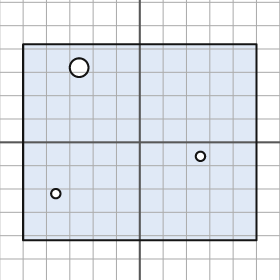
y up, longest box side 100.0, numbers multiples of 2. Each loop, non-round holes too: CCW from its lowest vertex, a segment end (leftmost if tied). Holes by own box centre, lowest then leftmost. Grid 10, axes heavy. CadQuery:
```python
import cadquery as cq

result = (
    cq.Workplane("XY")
    .moveTo(-50.0, -42.0)
    .lineTo(50.0, -42.0)
    .lineTo(50.0, 42.0)
    .lineTo(-50.0, 42.0)
    .close()
    .moveTo(-36.0, -22.0)
    .circle(2.0)
    .moveTo(26.0, -6.0)
    .circle(2.0)
    .moveTo(-26.0, 32.0)
    .circle(4.0)
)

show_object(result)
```